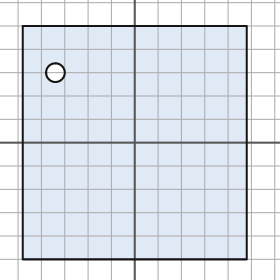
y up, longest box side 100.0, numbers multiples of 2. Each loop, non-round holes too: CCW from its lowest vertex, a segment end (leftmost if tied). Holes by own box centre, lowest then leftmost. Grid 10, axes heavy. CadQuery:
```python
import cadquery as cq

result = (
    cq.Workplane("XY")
    .moveTo(-48.0, -50.0)
    .lineTo(48.0, -50.0)
    .lineTo(48.0, 50.0)
    .lineTo(-48.0, 50.0)
    .close()
    .moveTo(-34.0, 30.0)
    .circle(4.0)
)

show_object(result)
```